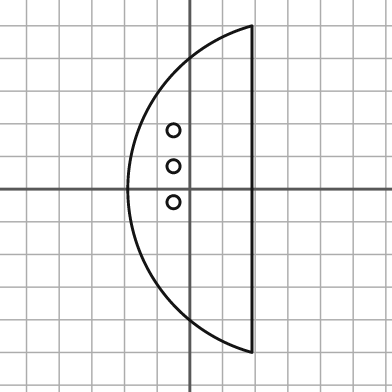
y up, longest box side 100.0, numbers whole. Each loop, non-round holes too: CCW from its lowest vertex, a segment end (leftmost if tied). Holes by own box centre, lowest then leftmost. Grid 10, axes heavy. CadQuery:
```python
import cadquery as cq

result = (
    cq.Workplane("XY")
    .moveTo(19.0, -50.0)
    .lineTo(19.0, 50.0)
    .threePointArc((-19.0, 0.0), (19.0, -50.0))
    .close()
    .moveTo(-5.0, -4.0)
    .circle(2.0)
    .moveTo(-5.0, 7.0)
    .circle(2.0)
    .moveTo(-5.0, 18.0)
    .circle(2.0)
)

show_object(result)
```